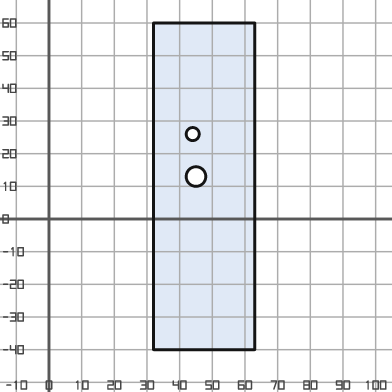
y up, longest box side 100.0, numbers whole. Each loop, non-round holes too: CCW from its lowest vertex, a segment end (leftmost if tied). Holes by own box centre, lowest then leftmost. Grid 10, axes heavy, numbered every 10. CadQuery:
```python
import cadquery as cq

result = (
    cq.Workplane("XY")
    .moveTo(32.0, -40.0)
    .lineTo(63.0, -40.0)
    .lineTo(63.0, 60.0)
    .lineTo(32.0, 60.0)
    .close()
    .moveTo(45.0, 13.0)
    .circle(3.0)
    .moveTo(44.0, 26.0)
    .circle(2.0)
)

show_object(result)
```